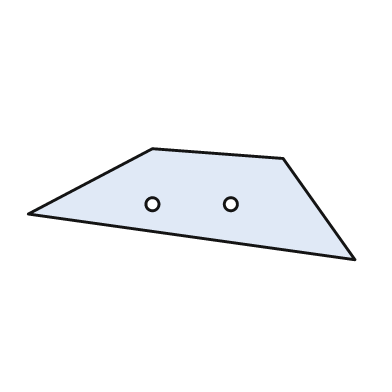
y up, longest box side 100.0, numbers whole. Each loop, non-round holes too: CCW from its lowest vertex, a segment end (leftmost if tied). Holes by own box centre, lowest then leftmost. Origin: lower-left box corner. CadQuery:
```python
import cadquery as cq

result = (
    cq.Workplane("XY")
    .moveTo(100.0, 0.0)
    .lineTo(78.0, 31.0)
    .lineTo(38.0, 34.0)
    .lineTo(0.0, 14.0)
    .close()
    .moveTo(38.0, 17.0)
    .circle(2.0)
    .moveTo(62.0, 17.0)
    .circle(2.0)
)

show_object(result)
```